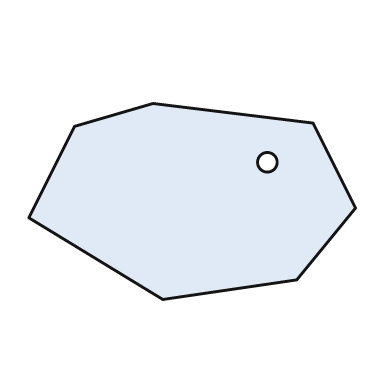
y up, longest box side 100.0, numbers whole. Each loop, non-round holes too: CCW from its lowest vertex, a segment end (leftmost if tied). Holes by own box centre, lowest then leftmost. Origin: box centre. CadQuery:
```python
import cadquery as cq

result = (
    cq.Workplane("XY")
    .moveTo(-9.0, -30.0)
    .lineTo(32.0, -24.0)
    .lineTo(50.0, -2.0)
    .lineTo(37.0, 24.0)
    .lineTo(-12.0, 30.0)
    .lineTo(-36.0, 23.0)
    .lineTo(-50.0, -5.0)
    .close()
    .moveTo(23.0, 12.0)
    .circle(3.0)
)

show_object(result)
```